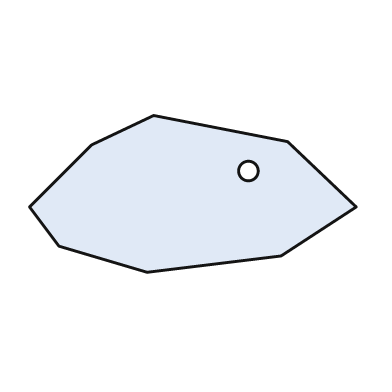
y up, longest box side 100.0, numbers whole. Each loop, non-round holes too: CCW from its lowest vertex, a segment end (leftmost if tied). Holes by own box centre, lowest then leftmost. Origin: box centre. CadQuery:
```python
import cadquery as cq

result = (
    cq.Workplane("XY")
    .moveTo(-14.0, -24.0)
    .lineTo(27.0, -19.0)
    .lineTo(50.0, -4.0)
    .lineTo(29.0, 16.0)
    .lineTo(-12.0, 24.0)
    .lineTo(-31.0, 15.0)
    .lineTo(-50.0, -4.0)
    .lineTo(-41.0, -16.0)
    .close()
    .moveTo(17.0, 7.0)
    .circle(3.0)
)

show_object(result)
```